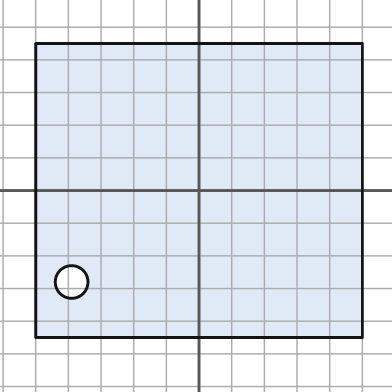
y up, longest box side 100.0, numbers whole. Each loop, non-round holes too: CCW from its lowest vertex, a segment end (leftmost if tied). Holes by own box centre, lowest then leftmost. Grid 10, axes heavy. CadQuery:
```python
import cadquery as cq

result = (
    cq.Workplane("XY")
    .moveTo(-50.0, -45.0)
    .lineTo(50.0, -45.0)
    .lineTo(50.0, 45.0)
    .lineTo(-50.0, 45.0)
    .close()
    .moveTo(-39.0, -28.0)
    .circle(5.0)
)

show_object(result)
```